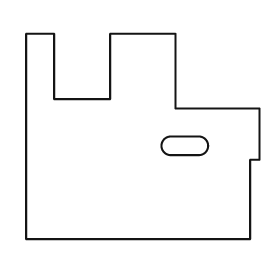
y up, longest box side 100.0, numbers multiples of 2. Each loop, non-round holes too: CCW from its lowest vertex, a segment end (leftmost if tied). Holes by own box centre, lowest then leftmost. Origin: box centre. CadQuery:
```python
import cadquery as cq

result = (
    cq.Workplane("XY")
    .moveTo(-50.0, -44.0)
    .lineTo(46.0, -44.0)
    .lineTo(46.0, -10.0)
    .lineTo(50.0, -10.0)
    .lineTo(50.0, 12.0)
    .lineTo(14.0, 12.0)
    .lineTo(14.0, 44.0)
    .lineTo(-14.0, 44.0)
    .lineTo(-14.0, 16.0)
    .lineTo(-38.0, 16.0)
    .lineTo(-38.0, 44.0)
    .lineTo(-50.0, 44.0)
    .close()
    .moveTo(12.0, -8.0)
    .lineTo(24.0, -8.0)
    .threePointArc((28.0, -4.0), (24.0, 0.0))
    .lineTo(12.0, 0.0)
    .threePointArc((8.0, -4.0), (12.0, -8.0))
    .close()
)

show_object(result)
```